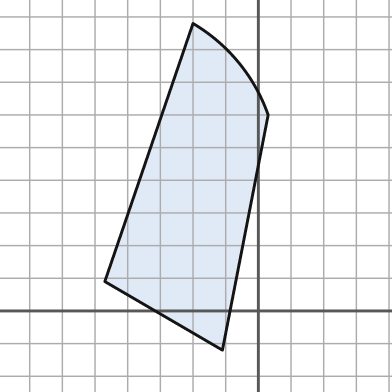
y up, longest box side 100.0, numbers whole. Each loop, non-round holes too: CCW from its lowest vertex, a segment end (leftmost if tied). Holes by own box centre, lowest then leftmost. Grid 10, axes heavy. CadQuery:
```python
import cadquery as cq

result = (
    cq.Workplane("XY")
    .moveTo(-11.0, -12.0)
    .lineTo(3.0, 60.0)
    .threePointArc((-6.0, 76.0), (-20.0, 88.0))
    .lineTo(-47.0, 9.0)
    .close()
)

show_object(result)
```